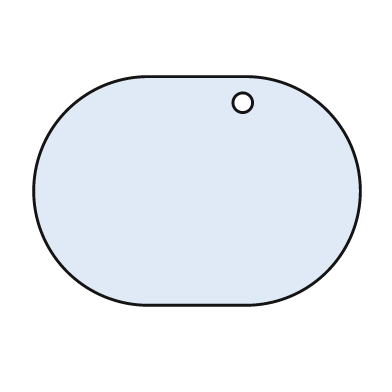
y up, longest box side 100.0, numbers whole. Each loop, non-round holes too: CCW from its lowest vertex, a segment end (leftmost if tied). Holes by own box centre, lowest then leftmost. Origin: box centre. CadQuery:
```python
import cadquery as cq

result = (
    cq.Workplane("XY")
    .moveTo(-15.0, -35.0)
    .lineTo(15.0, -35.0)
    .threePointArc((50.0, 0.0), (15.0, 35.0))
    .lineTo(-15.0, 35.0)
    .threePointArc((-50.0, 0.0), (-15.0, -35.0))
    .close()
    .moveTo(14.0, 27.0)
    .circle(3.0)
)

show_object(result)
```